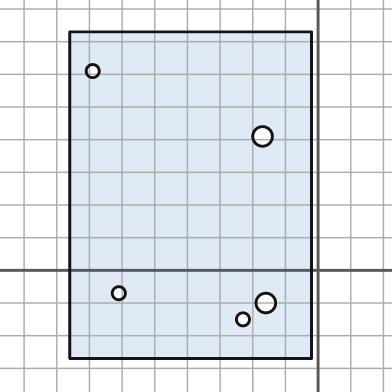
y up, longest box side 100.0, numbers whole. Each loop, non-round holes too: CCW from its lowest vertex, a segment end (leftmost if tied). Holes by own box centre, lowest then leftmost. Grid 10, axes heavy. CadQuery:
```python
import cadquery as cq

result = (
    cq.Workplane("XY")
    .moveTo(-76.0, -27.0)
    .lineTo(-2.0, -27.0)
    .lineTo(-2.0, 73.0)
    .lineTo(-76.0, 73.0)
    .close()
    .moveTo(-23.0, -15.0)
    .circle(2.0)
    .moveTo(-16.0, -10.0)
    .circle(3.0)
    .moveTo(-61.0, -7.0)
    .circle(2.0)
    .moveTo(-17.0, 41.0)
    .circle(3.0)
    .moveTo(-69.0, 61.0)
    .circle(2.0)
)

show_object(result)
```